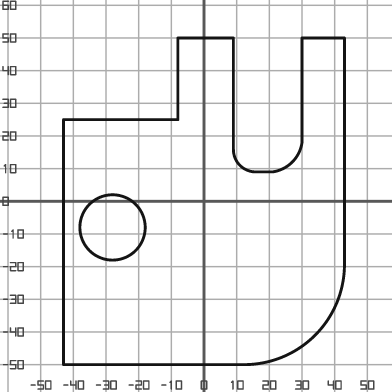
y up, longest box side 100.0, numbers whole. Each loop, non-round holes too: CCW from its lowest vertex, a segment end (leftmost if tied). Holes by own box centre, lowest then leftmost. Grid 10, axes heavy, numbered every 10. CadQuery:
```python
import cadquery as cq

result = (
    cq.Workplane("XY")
    .moveTo(-43.0, -50.0)
    .lineTo(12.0, -50.0)
    .threePointArc((34.0, -41.0), (43.0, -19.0))
    .lineTo(43.0, 50.0)
    .lineTo(30.0, 50.0)
    .lineTo(30.0, 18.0)
    .threePointArc((27.0, 12.0), (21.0, 9.0))
    .lineTo(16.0, 9.0)
    .threePointArc((11.0, 11.0), (9.0, 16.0))
    .lineTo(9.0, 50.0)
    .lineTo(-8.0, 50.0)
    .lineTo(-8.0, 25.0)
    .lineTo(-43.0, 25.0)
    .close()
    .moveTo(-28.0, -8.0)
    .circle(10.0)
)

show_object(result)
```